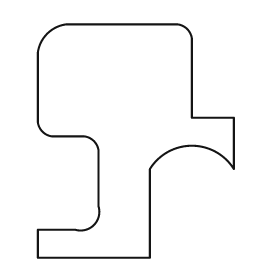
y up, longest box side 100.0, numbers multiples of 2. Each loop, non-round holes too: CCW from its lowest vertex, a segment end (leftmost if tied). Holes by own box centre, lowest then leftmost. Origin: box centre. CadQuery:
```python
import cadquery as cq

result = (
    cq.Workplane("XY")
    .moveTo(-42.0, -50.0)
    .lineTo(6.0, -50.0)
    .lineTo(6.0, -12.0)
    .threePointArc((24.0, -2.0), (42.0, -12.0))
    .lineTo(42.0, 10.0)
    .lineTo(24.0, 10.0)
    .lineTo(24.0, 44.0)
    .threePointArc((22.0, 48.0), (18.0, 50.0))
    .lineTo(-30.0, 50.0)
    .threePointArc((-38.0, 46.0), (-42.0, 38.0))
    .lineTo(-42.0, 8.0)
    .threePointArc((-40.0, 4.0), (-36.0, 2.0))
    .lineTo(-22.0, 2.0)
    .threePointArc((-18.0, 0.0), (-16.0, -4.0))
    .lineTo(-16.0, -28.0)
    .threePointArc((-18.0, -36.0), (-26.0, -38.0))
    .lineTo(-42.0, -38.0)
    .close()
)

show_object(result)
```